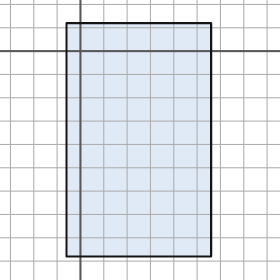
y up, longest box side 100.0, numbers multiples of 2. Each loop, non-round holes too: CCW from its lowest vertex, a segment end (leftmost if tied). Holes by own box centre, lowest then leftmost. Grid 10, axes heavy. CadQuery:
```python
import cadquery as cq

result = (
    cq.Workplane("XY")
    .moveTo(-6.0, -88.0)
    .lineTo(56.0, -88.0)
    .lineTo(56.0, 12.0)
    .lineTo(-6.0, 12.0)
    .close()
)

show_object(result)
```